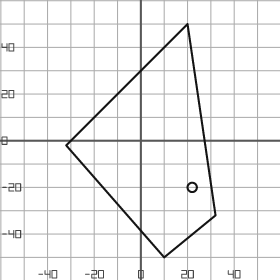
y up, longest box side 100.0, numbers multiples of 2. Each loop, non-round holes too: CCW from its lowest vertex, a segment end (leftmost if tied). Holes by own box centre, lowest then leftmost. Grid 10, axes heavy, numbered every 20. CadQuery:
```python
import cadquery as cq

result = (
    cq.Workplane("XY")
    .moveTo(10.0, -50.0)
    .lineTo(32.0, -32.0)
    .lineTo(20.0, 50.0)
    .lineTo(-32.0, -2.0)
    .close()
    .moveTo(22.0, -20.0)
    .circle(2.0)
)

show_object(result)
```